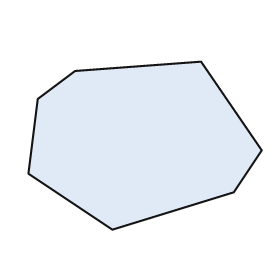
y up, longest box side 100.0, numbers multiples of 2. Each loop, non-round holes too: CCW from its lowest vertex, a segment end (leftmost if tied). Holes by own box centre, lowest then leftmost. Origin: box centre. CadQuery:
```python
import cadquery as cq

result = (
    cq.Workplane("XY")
    .moveTo(-14.0, -36.0)
    .lineTo(38.0, -20.0)
    .lineTo(50.0, -2.0)
    .lineTo(24.0, 36.0)
    .lineTo(-30.0, 32.0)
    .lineTo(-46.0, 20.0)
    .lineTo(-50.0, -12.0)
    .close()
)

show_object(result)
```